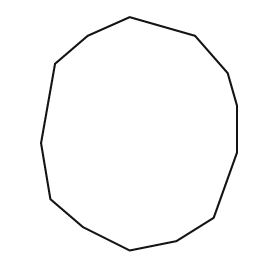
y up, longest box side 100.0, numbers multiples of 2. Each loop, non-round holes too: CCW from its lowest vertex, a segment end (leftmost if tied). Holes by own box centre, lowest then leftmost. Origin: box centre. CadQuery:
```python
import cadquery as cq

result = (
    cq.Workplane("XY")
    .moveTo(-4.0, -50.0)
    .lineTo(16.0, -46.0)
    .lineTo(32.0, -36.0)
    .lineTo(42.0, -8.0)
    .lineTo(42.0, 12.0)
    .lineTo(38.0, 26.0)
    .lineTo(24.0, 42.0)
    .lineTo(-4.0, 50.0)
    .lineTo(-22.0, 42.0)
    .lineTo(-36.0, 30.0)
    .lineTo(-42.0, -4.0)
    .lineTo(-38.0, -28.0)
    .lineTo(-24.0, -40.0)
    .close()
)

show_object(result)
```